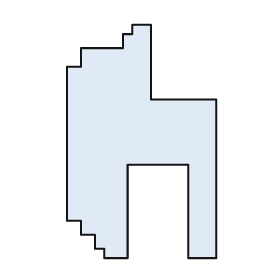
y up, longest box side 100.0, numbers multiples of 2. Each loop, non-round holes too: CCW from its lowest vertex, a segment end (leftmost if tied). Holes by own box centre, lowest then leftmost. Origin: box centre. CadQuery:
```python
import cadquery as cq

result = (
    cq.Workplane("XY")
    .moveTo(-16.0, -50.0)
    .lineTo(-6.0, -50.0)
    .lineTo(-6.0, -10.0)
    .lineTo(20.0, -10.0)
    .lineTo(20.0, -50.0)
    .lineTo(32.0, -50.0)
    .lineTo(32.0, 18.0)
    .lineTo(4.0, 18.0)
    .lineTo(4.0, 50.0)
    .lineTo(-4.0, 50.0)
    .lineTo(-4.0, 46.0)
    .lineTo(-8.0, 46.0)
    .lineTo(-8.0, 40.0)
    .lineTo(-26.0, 40.0)
    .lineTo(-26.0, 32.0)
    .lineTo(-32.0, 32.0)
    .lineTo(-32.0, -34.0)
    .lineTo(-26.0, -34.0)
    .lineTo(-26.0, -40.0)
    .lineTo(-20.0, -40.0)
    .lineTo(-20.0, -46.0)
    .lineTo(-16.0, -46.0)
    .close()
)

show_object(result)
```